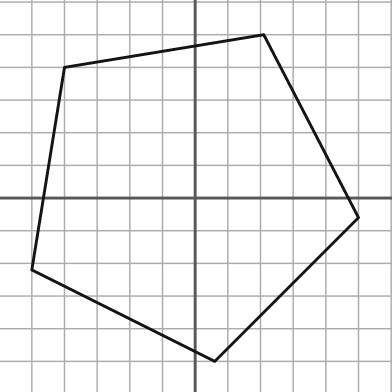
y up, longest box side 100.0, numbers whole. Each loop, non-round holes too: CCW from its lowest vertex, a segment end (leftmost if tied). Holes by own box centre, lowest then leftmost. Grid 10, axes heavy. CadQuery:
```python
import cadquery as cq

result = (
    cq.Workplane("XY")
    .moveTo(6.0, -50.0)
    .lineTo(50.0, -6.0)
    .lineTo(21.0, 50.0)
    .lineTo(-40.0, 40.0)
    .lineTo(-50.0, -22.0)
    .close()
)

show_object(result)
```